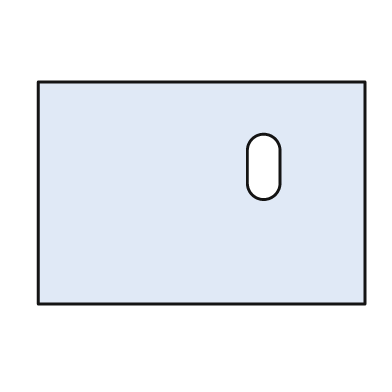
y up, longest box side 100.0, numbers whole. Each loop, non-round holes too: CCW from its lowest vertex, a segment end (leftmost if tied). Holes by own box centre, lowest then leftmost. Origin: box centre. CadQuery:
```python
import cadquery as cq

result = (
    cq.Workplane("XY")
    .moveTo(-50.0, -34.0)
    .lineTo(50.0, -34.0)
    .lineTo(50.0, 34.0)
    .lineTo(-50.0, 34.0)
    .close()
    .moveTo(14.0, 3.0)
    .threePointArc((19.0, -2.0), (24.0, 3.0))
    .lineTo(24.0, 13.0)
    .threePointArc((19.0, 18.0), (14.0, 13.0))
    .close()
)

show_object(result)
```